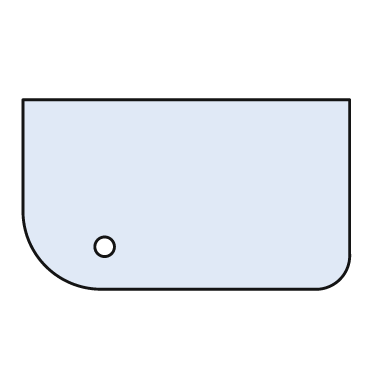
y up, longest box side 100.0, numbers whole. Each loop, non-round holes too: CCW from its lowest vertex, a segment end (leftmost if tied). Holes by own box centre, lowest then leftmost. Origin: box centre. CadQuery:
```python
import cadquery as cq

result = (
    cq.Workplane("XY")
    .moveTo(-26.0, -29.0)
    .lineTo(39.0, -29.0)
    .threePointArc((47.0, -26.0), (50.0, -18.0))
    .lineTo(50.0, 29.0)
    .lineTo(-50.0, 29.0)
    .lineTo(-50.0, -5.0)
    .threePointArc((-43.0, -22.0), (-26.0, -29.0))
    .close()
    .moveTo(-25.0, -16.0)
    .circle(3.0)
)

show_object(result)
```